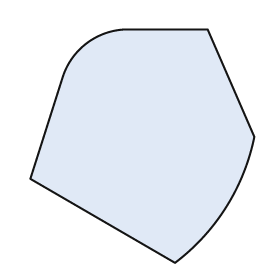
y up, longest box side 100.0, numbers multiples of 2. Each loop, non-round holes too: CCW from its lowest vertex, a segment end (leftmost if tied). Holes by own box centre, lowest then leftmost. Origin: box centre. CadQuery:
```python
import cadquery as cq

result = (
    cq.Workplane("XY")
    .moveTo(14.0, -50.0)
    .threePointArc((36.0, -26.0), (48.0, 4.0))
    .lineTo(28.0, 50.0)
    .lineTo(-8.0, 50.0)
    .threePointArc((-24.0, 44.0), (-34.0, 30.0))
    .lineTo(-48.0, -14.0)
    .close()
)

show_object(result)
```